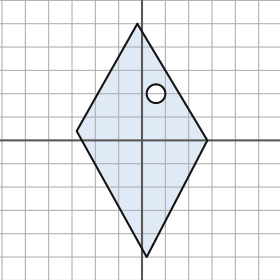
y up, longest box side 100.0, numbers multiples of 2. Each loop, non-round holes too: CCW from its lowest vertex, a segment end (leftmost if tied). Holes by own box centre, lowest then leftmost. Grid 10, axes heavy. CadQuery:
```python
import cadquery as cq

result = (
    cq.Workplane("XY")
    .moveTo(2.0, -50.0)
    .lineTo(28.0, 0.0)
    .lineTo(-2.0, 50.0)
    .lineTo(-28.0, 4.0)
    .close()
    .moveTo(6.0, 20.0)
    .circle(4.0)
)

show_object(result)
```